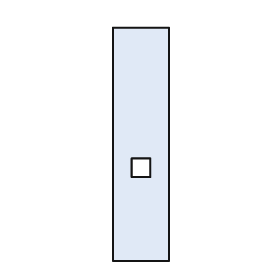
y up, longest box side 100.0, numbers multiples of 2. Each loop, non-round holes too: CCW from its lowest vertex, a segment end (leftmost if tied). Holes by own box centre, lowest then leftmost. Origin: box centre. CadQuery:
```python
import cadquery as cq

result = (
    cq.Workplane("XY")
    .moveTo(-12.0, -50.0)
    .lineTo(12.0, -50.0)
    .lineTo(12.0, 50.0)
    .lineTo(-12.0, 50.0)
    .close()
    .moveTo(-4.0, -14.0)
    .lineTo(4.0, -14.0)
    .lineTo(4.0, -6.0)
    .lineTo(-4.0, -6.0)
    .close()
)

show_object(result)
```